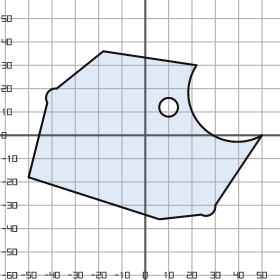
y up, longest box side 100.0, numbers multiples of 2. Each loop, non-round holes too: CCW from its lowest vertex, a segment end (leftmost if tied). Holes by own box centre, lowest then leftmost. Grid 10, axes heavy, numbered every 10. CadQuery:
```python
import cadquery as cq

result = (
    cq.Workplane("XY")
    .moveTo(6.0, -36.0)
    .lineTo(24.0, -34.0)
    .threePointArc((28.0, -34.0), (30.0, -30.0))
    .lineTo(50.0, 0.0)
    .threePointArc((24.0, 4.0), (22.0, 30.0))
    .lineTo(-18.0, 36.0)
    .lineTo(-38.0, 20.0)
    .threePointArc((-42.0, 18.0), (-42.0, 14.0))
    .lineTo(-50.0, -18.0)
    .close()
    .moveTo(10.0, 12.0)
    .circle(4.0)
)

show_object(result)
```